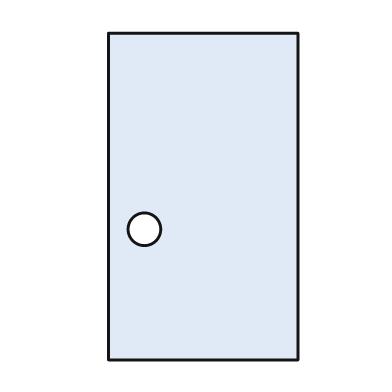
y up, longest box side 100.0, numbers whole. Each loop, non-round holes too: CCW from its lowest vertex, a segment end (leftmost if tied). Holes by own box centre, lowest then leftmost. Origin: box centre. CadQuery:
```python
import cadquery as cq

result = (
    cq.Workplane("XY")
    .moveTo(-29.0, -50.0)
    .lineTo(29.0, -50.0)
    .lineTo(29.0, 50.0)
    .lineTo(-29.0, 50.0)
    .close()
    .moveTo(-18.0, -10.0)
    .circle(5.0)
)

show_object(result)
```